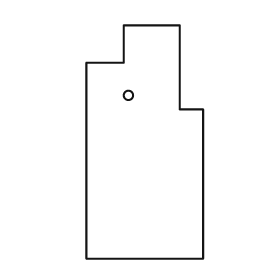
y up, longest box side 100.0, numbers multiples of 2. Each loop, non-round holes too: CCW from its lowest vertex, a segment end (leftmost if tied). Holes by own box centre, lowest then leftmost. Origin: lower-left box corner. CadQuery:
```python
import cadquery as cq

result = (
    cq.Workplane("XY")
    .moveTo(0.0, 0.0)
    .lineTo(50.0, 0.0)
    .lineTo(50.0, 64.0)
    .lineTo(40.0, 64.0)
    .lineTo(40.0, 100.0)
    .lineTo(16.0, 100.0)
    .lineTo(16.0, 84.0)
    .lineTo(0.0, 84.0)
    .close()
    .moveTo(18.0, 70.0)
    .circle(2.0)
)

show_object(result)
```